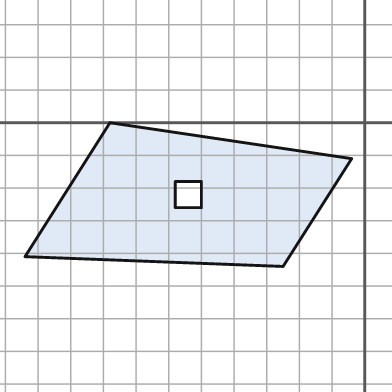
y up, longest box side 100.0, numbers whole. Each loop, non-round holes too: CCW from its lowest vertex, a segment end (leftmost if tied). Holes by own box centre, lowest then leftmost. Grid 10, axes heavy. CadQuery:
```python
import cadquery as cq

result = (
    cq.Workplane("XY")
    .moveTo(-25.0, -44.0)
    .lineTo(-4.0, -11.0)
    .lineTo(-78.0, 0.0)
    .lineTo(-104.0, -41.0)
    .close()
    .moveTo(-58.0, -26.0)
    .lineTo(-50.0, -26.0)
    .lineTo(-50.0, -18.0)
    .lineTo(-58.0, -18.0)
    .close()
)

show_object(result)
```